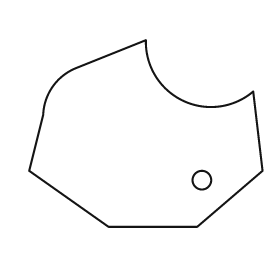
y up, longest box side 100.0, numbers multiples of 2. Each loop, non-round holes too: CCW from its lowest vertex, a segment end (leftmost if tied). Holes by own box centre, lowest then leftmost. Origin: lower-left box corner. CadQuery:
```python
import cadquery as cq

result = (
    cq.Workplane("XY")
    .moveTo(34.0, 0.0)
    .lineTo(72.0, 0.0)
    .lineTo(100.0, 24.0)
    .lineTo(96.0, 58.0)
    .threePointArc((66.0, 54.0), (50.0, 80.0))
    .lineTo(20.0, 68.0)
    .threePointArc((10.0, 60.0), (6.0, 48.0))
    .lineTo(0.0, 24.0)
    .close()
    .moveTo(74.0, 20.0)
    .circle(4.0)
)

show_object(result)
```